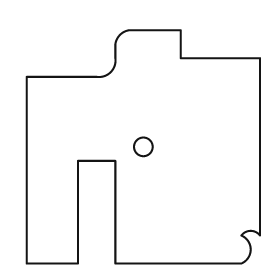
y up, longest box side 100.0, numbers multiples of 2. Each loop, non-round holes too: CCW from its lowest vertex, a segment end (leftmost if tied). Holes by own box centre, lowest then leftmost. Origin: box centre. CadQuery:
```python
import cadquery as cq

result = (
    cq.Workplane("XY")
    .moveTo(-50.0, -50.0)
    .lineTo(-28.0, -50.0)
    .lineTo(-28.0, -6.0)
    .lineTo(-12.0, -6.0)
    .lineTo(-12.0, -50.0)
    .lineTo(42.0, -50.0)
    .threePointArc((46.0, -44.0), (42.0, -38.0))
    .threePointArc((46.0, -36.0), (50.0, -38.0))
    .lineTo(50.0, 38.0)
    .lineTo(16.0, 38.0)
    .lineTo(16.0, 50.0)
    .lineTo(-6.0, 50.0)
    .threePointArc((-10.0, 48.0), (-12.0, 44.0))
    .lineTo(-12.0, 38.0)
    .threePointArc((-14.0, 32.0), (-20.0, 30.0))
    .lineTo(-50.0, 30.0)
    .close()
    .moveTo(0.0, 0.0)
    .circle(4.0)
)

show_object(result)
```